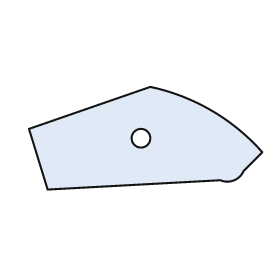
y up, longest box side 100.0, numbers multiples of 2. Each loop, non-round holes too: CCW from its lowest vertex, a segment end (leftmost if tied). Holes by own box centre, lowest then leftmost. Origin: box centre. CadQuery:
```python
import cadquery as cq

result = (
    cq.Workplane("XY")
    .moveTo(-42.0, -22.0)
    .lineTo(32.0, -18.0)
    .threePointArc((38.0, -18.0), (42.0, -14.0))
    .lineTo(50.0, -6.0)
    .threePointArc((28.0, 12.0), (2.0, 22.0))
    .lineTo(-50.0, 4.0)
    .close()
    .moveTo(-2.0, 0.0)
    .circle(4.0)
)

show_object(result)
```